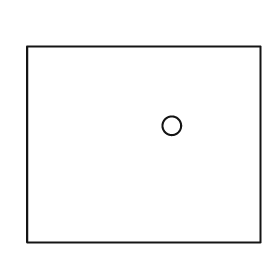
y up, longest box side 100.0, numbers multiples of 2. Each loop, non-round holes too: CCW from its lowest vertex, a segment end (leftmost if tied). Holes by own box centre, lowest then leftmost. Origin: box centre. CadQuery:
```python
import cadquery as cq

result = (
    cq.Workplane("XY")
    .moveTo(-50.0, -42.0)
    .lineTo(50.0, -42.0)
    .lineTo(50.0, 42.0)
    .lineTo(-50.0, 42.0)
    .close()
    .moveTo(12.0, 8.0)
    .circle(4.0)
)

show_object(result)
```